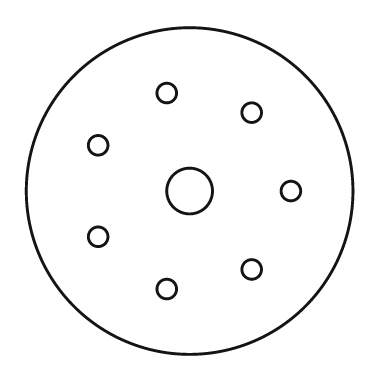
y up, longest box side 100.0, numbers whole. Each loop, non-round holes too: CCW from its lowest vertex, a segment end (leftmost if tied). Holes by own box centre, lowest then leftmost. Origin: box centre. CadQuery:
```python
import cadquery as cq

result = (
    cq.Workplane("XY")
    .moveTo(0.0, 0.0)
    .circle(50.0)
    .moveTo(-7.0, -30.0)
    .circle(3.0)
    .moveTo(19.0, -24.0)
    .circle(3.0)
    .moveTo(-28.0, -14.0)
    .circle(3.0)
    .moveTo(0.0, 0.0)
    .circle(7.0)
    .moveTo(31.0, 0.0)
    .circle(3.0)
    .moveTo(-28.0, 14.0)
    .circle(3.0)
    .moveTo(19.0, 24.0)
    .circle(3.0)
    .moveTo(-7.0, 30.0)
    .circle(3.0)
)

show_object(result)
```